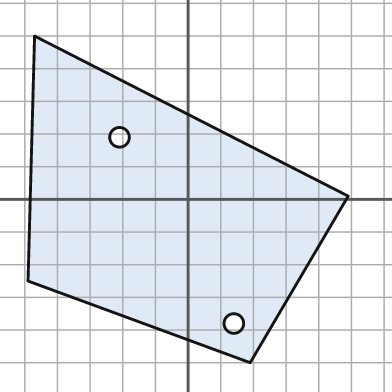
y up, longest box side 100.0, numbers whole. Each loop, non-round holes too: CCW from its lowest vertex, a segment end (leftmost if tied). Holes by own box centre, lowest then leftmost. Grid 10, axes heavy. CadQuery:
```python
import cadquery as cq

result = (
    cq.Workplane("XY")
    .moveTo(19.0, -50.0)
    .lineTo(49.0, 1.0)
    .lineTo(-47.0, 50.0)
    .lineTo(-49.0, -25.0)
    .close()
    .moveTo(14.0, -38.0)
    .circle(3.0)
    .moveTo(-21.0, 19.0)
    .circle(3.0)
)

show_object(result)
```